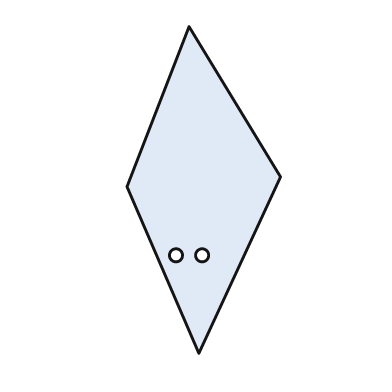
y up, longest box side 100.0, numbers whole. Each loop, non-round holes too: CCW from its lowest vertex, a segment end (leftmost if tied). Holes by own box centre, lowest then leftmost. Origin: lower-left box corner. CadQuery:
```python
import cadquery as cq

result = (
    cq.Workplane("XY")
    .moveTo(22.0, 0.0)
    .lineTo(47.0, 54.0)
    .lineTo(19.0, 100.0)
    .lineTo(0.0, 51.0)
    .close()
    .moveTo(15.0, 30.0)
    .circle(2.0)
    .moveTo(23.0, 30.0)
    .circle(2.0)
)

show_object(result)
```